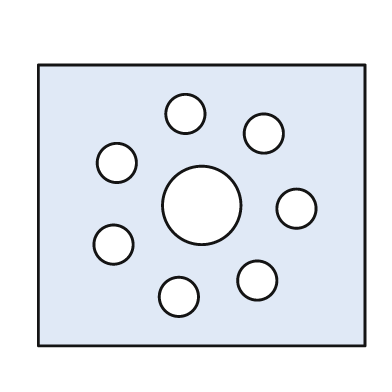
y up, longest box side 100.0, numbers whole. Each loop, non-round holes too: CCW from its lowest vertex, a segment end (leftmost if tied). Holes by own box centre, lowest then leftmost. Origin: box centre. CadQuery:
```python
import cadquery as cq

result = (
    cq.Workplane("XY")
    .moveTo(-50.0, -43.0)
    .lineTo(50.0, -43.0)
    .lineTo(50.0, 43.0)
    .lineTo(-50.0, 43.0)
    .close()
    .moveTo(-7.0, -28.0)
    .circle(6.0)
    .moveTo(17.0, -23.0)
    .circle(6.0)
    .moveTo(-27.0, -12.0)
    .circle(6.0)
    .moveTo(29.0, -1.0)
    .circle(6.0)
    .moveTo(0.0, 0.0)
    .circle(12.0)
    .moveTo(-26.0, 13.0)
    .circle(6.0)
    .moveTo(19.0, 22.0)
    .circle(6.0)
    .moveTo(-5.0, 28.0)
    .circle(6.0)
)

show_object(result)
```